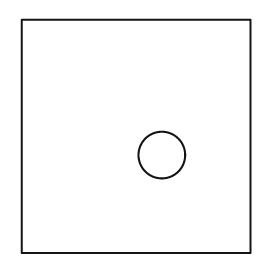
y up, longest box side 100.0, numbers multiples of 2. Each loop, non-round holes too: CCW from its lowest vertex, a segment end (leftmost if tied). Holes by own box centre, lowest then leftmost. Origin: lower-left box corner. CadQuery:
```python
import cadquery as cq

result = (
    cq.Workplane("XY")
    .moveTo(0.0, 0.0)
    .lineTo(98.0, 0.0)
    .lineTo(98.0, 100.0)
    .lineTo(0.0, 100.0)
    .close()
    .moveTo(60.0, 42.0)
    .circle(10.0)
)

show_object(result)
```